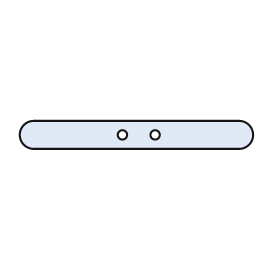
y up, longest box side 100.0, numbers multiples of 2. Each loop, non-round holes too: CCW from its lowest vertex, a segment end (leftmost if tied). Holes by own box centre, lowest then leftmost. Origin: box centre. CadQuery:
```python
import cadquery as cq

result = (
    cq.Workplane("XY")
    .moveTo(-44.0, -6.0)
    .lineTo(44.0, -6.0)
    .threePointArc((50.0, 0.0), (44.0, 6.0))
    .lineTo(-44.0, 6.0)
    .threePointArc((-50.0, 0.0), (-44.0, -6.0))
    .close()
    .moveTo(-6.0, 0.0)
    .circle(2.0)
    .moveTo(8.0, 0.0)
    .circle(2.0)
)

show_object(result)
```